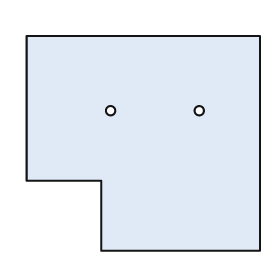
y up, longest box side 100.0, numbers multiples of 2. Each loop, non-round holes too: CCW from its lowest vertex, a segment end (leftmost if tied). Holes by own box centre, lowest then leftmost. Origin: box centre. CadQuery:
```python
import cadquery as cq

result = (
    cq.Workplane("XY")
    .moveTo(-18.0, -46.0)
    .lineTo(50.0, -46.0)
    .lineTo(50.0, 46.0)
    .lineTo(-50.0, 46.0)
    .lineTo(-50.0, -16.0)
    .lineTo(-18.0, -16.0)
    .close()
    .moveTo(-14.0, 14.0)
    .circle(2.0)
    .moveTo(24.0, 14.0)
    .circle(2.0)
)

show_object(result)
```